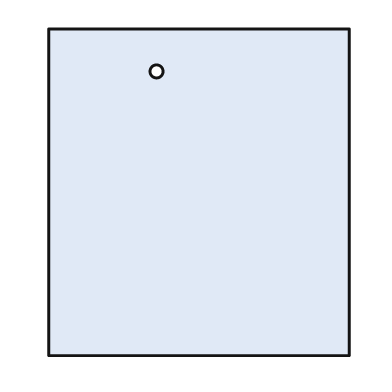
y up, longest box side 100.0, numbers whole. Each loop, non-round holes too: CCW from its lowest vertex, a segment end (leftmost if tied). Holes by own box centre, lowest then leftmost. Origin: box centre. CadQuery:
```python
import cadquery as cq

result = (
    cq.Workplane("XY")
    .moveTo(-46.0, -50.0)
    .lineTo(46.0, -50.0)
    .lineTo(46.0, 50.0)
    .lineTo(-46.0, 50.0)
    .close()
    .moveTo(-13.0, 37.0)
    .circle(2.0)
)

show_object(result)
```